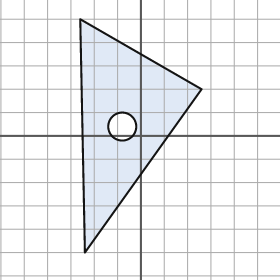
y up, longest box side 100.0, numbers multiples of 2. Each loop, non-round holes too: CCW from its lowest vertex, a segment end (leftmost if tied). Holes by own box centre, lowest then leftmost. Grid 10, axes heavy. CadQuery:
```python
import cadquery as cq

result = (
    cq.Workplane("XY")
    .moveTo(-24.0, -50.0)
    .lineTo(26.0, 20.0)
    .lineTo(-26.0, 50.0)
    .close()
    .moveTo(-8.0, 4.0)
    .circle(6.0)
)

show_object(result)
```